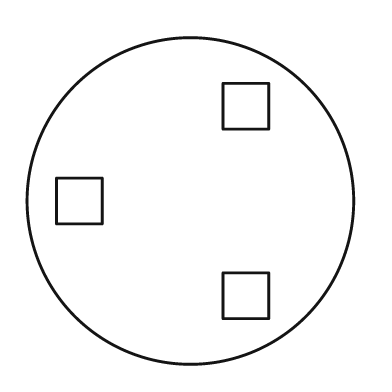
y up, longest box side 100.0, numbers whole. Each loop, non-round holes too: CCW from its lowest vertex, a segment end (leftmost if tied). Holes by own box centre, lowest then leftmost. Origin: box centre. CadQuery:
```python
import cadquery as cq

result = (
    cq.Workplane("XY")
    .moveTo(0.0, 0.0)
    .circle(50.0)
    .moveTo(10.0, -36.0)
    .lineTo(24.0, -36.0)
    .lineTo(24.0, -22.0)
    .lineTo(10.0, -22.0)
    .close()
    .moveTo(-41.0, -7.0)
    .lineTo(-27.0, -7.0)
    .lineTo(-27.0, 7.0)
    .lineTo(-41.0, 7.0)
    .close()
    .moveTo(10.0, 22.0)
    .lineTo(24.0, 22.0)
    .lineTo(24.0, 36.0)
    .lineTo(10.0, 36.0)
    .close()
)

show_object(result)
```